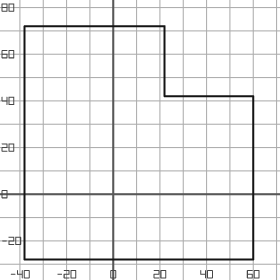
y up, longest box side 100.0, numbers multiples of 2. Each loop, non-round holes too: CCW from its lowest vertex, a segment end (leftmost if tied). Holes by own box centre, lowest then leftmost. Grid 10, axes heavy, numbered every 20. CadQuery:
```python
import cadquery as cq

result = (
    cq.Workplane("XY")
    .moveTo(-38.0, -28.0)
    .lineTo(60.0, -28.0)
    .lineTo(60.0, 42.0)
    .lineTo(22.0, 42.0)
    .lineTo(22.0, 72.0)
    .lineTo(-38.0, 72.0)
    .close()
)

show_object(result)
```